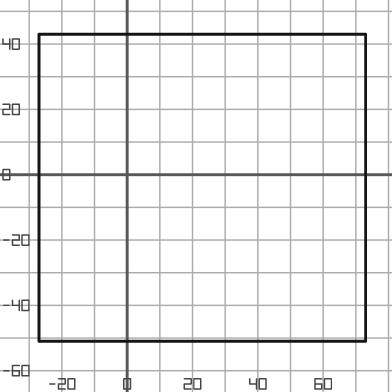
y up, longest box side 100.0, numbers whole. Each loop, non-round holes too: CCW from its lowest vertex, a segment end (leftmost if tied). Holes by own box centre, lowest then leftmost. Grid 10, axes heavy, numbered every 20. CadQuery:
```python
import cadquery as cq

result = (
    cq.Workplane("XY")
    .moveTo(-27.0, -51.0)
    .lineTo(73.0, -51.0)
    .lineTo(73.0, 43.0)
    .lineTo(-27.0, 43.0)
    .close()
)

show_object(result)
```